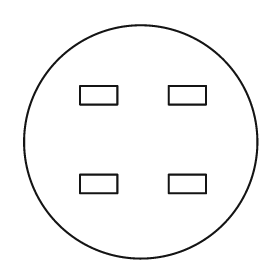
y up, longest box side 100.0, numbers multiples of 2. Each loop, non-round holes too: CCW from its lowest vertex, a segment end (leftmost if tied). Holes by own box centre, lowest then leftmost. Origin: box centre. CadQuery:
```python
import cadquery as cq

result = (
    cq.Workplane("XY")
    .moveTo(0.0, 0.0)
    .circle(50.0)
    .moveTo(-26.0, -22.0)
    .lineTo(-10.0, -22.0)
    .lineTo(-10.0, -14.0)
    .lineTo(-26.0, -14.0)
    .close()
    .moveTo(12.0, -22.0)
    .lineTo(28.0, -22.0)
    .lineTo(28.0, -14.0)
    .lineTo(12.0, -14.0)
    .close()
    .moveTo(-26.0, 16.0)
    .lineTo(-10.0, 16.0)
    .lineTo(-10.0, 24.0)
    .lineTo(-26.0, 24.0)
    .close()
    .moveTo(12.0, 16.0)
    .lineTo(28.0, 16.0)
    .lineTo(28.0, 24.0)
    .lineTo(12.0, 24.0)
    .close()
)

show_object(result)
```